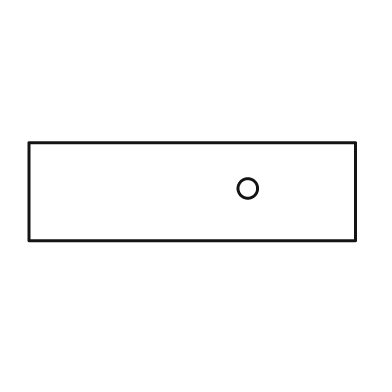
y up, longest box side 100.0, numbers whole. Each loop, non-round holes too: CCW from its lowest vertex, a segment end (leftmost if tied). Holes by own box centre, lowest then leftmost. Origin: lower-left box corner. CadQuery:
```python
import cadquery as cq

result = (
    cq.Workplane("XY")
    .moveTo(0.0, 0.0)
    .lineTo(100.0, 0.0)
    .lineTo(100.0, 30.0)
    .lineTo(0.0, 30.0)
    .close()
    .moveTo(67.0, 16.0)
    .circle(3.0)
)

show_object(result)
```